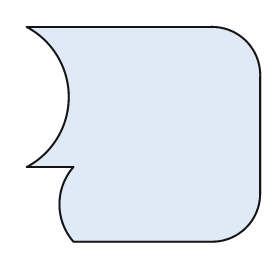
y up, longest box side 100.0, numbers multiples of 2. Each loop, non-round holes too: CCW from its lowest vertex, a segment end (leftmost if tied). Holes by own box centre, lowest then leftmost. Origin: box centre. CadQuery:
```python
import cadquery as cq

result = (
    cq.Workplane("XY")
    .moveTo(-30.0, -46.0)
    .lineTo(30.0, -46.0)
    .threePointArc((44.0, -40.0), (50.0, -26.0))
    .lineTo(50.0, 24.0)
    .threePointArc((44.0, 40.0), (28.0, 46.0))
    .lineTo(-50.0, 46.0)
    .threePointArc((-32.0, 16.0), (-50.0, -14.0))
    .lineTo(-30.0, -14.0)
    .threePointArc((-36.0, -30.0), (-30.0, -46.0))
    .close()
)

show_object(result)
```